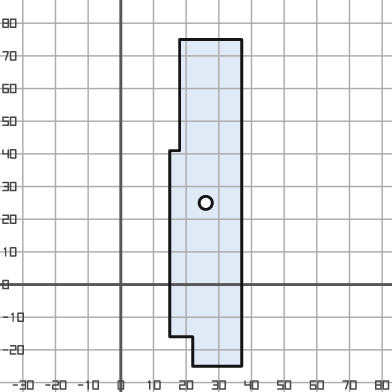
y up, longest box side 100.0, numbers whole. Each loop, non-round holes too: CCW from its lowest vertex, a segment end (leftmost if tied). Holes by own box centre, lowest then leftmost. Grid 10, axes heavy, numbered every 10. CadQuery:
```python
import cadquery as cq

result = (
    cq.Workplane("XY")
    .moveTo(22.0, -25.0)
    .lineTo(37.0, -25.0)
    .lineTo(37.0, 75.0)
    .lineTo(18.0, 75.0)
    .lineTo(18.0, 41.0)
    .lineTo(15.0, 41.0)
    .lineTo(15.0, -16.0)
    .lineTo(22.0, -16.0)
    .close()
    .moveTo(26.0, 25.0)
    .circle(2.0)
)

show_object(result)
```